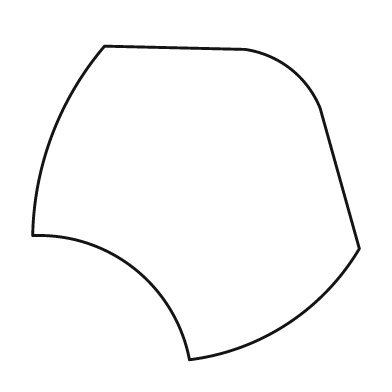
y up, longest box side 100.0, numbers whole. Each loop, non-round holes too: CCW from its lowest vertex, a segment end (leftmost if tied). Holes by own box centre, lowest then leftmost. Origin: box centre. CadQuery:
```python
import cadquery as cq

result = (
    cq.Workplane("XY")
    .moveTo(-2.0, -48.0)
    .threePointArc((28.0, -37.0), (50.0, -14.0))
    .lineTo(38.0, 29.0)
    .threePointArc((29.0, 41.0), (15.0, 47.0))
    .lineTo(-28.0, 48.0)
    .threePointArc((-44.0, 21.0), (-50.0, -10.0))
    .threePointArc((-19.0, -20.0), (-2.0, -48.0))
    .close()
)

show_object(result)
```